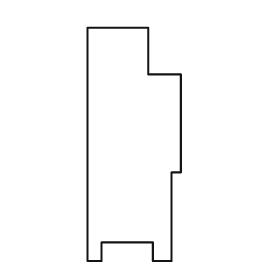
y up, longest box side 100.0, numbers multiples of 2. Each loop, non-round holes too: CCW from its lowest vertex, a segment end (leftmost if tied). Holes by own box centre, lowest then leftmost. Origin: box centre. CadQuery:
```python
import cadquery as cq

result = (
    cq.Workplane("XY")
    .moveTo(-20.0, -50.0)
    .lineTo(-14.0, -50.0)
    .lineTo(-14.0, -42.0)
    .lineTo(8.0, -42.0)
    .lineTo(8.0, -50.0)
    .lineTo(16.0, -50.0)
    .lineTo(16.0, -12.0)
    .lineTo(20.0, -12.0)
    .lineTo(20.0, 30.0)
    .lineTo(6.0, 30.0)
    .lineTo(6.0, 50.0)
    .lineTo(-20.0, 50.0)
    .close()
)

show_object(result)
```